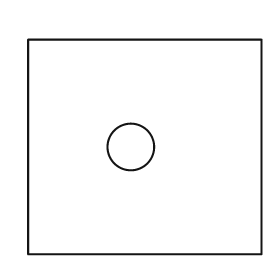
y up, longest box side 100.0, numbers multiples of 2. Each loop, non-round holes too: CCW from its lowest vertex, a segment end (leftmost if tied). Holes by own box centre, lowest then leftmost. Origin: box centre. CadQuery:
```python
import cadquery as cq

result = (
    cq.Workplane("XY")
    .moveTo(-50.0, -46.0)
    .lineTo(50.0, -46.0)
    .lineTo(50.0, 46.0)
    .lineTo(-50.0, 46.0)
    .close()
    .moveTo(-6.0, 0.0)
    .circle(10.0)
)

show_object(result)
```